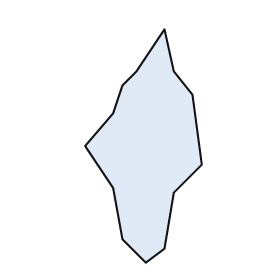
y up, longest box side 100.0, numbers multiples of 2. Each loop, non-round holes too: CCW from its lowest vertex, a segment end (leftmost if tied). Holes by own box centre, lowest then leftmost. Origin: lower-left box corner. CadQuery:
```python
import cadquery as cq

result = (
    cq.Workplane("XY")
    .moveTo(26.0, 0.0)
    .lineTo(34.0, 6.0)
    .lineTo(38.0, 30.0)
    .lineTo(50.0, 42.0)
    .lineTo(46.0, 72.0)
    .lineTo(38.0, 82.0)
    .lineTo(34.0, 100.0)
    .lineTo(22.0, 82.0)
    .lineTo(16.0, 76.0)
    .lineTo(12.0, 64.0)
    .lineTo(0.0, 50.0)
    .lineTo(12.0, 32.0)
    .lineTo(16.0, 10.0)
    .close()
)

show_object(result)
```